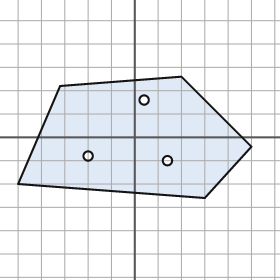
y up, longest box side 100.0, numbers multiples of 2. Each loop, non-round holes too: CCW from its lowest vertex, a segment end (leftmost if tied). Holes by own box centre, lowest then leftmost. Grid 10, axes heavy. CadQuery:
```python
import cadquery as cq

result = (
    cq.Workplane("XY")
    .moveTo(30.0, -26.0)
    .lineTo(50.0, -4.0)
    .lineTo(20.0, 26.0)
    .lineTo(-32.0, 22.0)
    .lineTo(-50.0, -20.0)
    .close()
    .moveTo(14.0, -10.0)
    .circle(2.0)
    .moveTo(-20.0, -8.0)
    .circle(2.0)
    .moveTo(4.0, 16.0)
    .circle(2.0)
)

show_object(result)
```